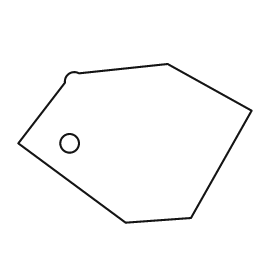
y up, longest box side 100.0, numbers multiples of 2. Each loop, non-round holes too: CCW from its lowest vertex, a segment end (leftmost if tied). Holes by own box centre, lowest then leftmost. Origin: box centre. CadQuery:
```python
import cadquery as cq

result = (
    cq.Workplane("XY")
    .moveTo(-4.0, -34.0)
    .lineTo(24.0, -32.0)
    .lineTo(50.0, 14.0)
    .lineTo(14.0, 34.0)
    .lineTo(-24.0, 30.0)
    .threePointArc((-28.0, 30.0), (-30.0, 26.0))
    .lineTo(-50.0, 0.0)
    .close()
    .moveTo(-28.0, 0.0)
    .circle(4.0)
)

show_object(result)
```